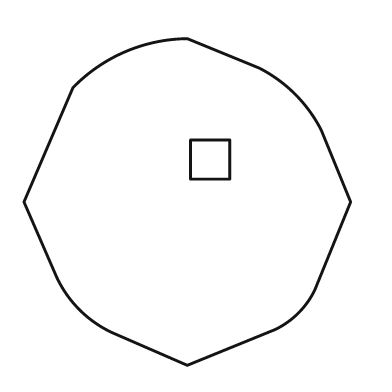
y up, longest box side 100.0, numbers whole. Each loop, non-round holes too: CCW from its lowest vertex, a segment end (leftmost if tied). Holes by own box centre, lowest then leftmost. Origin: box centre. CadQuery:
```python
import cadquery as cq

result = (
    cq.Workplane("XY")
    .moveTo(0.0, -50.0)
    .lineTo(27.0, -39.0)
    .threePointArc((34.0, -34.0), (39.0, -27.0))
    .lineTo(50.0, 0.0)
    .lineTo(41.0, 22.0)
    .threePointArc((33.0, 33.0), (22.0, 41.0))
    .lineTo(0.0, 50.0)
    .threePointArc((-19.0, 46.0), (-35.0, 35.0))
    .lineTo(-50.0, 0.0)
    .lineTo(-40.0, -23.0)
    .threePointArc((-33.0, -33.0), (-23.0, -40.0))
    .close()
    .moveTo(1.0, 7.0)
    .lineTo(13.0, 7.0)
    .lineTo(13.0, 19.0)
    .lineTo(1.0, 19.0)
    .close()
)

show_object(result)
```